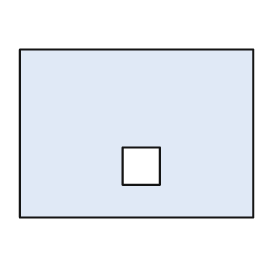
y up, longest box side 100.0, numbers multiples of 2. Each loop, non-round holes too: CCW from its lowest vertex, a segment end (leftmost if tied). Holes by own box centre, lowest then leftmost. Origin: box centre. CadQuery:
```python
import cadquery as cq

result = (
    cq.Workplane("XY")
    .moveTo(-50.0, -36.0)
    .lineTo(50.0, -36.0)
    .lineTo(50.0, 36.0)
    .lineTo(-50.0, 36.0)
    .close()
    .moveTo(-6.0, -22.0)
    .lineTo(10.0, -22.0)
    .lineTo(10.0, -6.0)
    .lineTo(-6.0, -6.0)
    .close()
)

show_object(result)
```